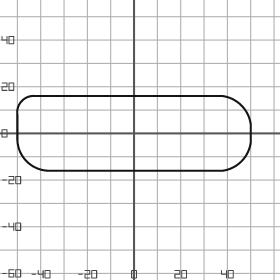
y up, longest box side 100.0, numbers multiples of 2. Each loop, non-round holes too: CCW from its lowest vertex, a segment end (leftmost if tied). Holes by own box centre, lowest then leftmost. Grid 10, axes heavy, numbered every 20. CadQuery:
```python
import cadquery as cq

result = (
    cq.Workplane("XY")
    .moveTo(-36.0, -16.0)
    .lineTo(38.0, -16.0)
    .threePointArc((46.0, -12.0), (50.0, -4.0))
    .lineTo(50.0, 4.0)
    .threePointArc((46.0, 12.0), (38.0, 16.0))
    .lineTo(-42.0, 16.0)
    .threePointArc((-48.0, 14.0), (-50.0, 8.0))
    .lineTo(-50.0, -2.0)
    .threePointArc((-46.0, -12.0), (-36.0, -16.0))
    .close()
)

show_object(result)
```